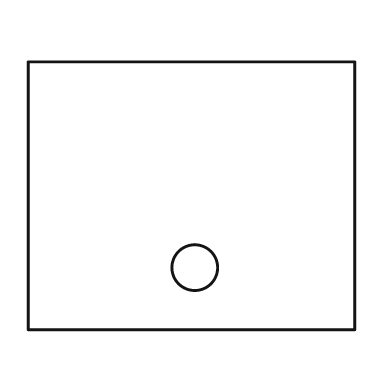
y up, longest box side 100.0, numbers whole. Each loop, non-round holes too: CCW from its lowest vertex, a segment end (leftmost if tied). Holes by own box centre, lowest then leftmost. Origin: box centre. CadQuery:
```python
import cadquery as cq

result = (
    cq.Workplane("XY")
    .moveTo(-50.0, -41.0)
    .lineTo(50.0, -41.0)
    .lineTo(50.0, 41.0)
    .lineTo(-50.0, 41.0)
    .close()
    .moveTo(1.0, -22.0)
    .circle(7.0)
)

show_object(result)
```